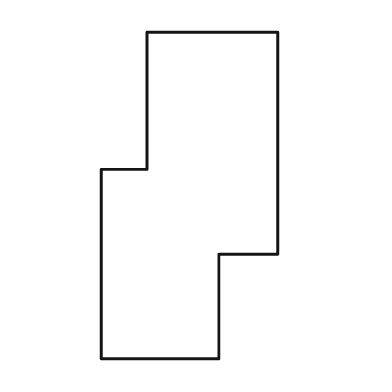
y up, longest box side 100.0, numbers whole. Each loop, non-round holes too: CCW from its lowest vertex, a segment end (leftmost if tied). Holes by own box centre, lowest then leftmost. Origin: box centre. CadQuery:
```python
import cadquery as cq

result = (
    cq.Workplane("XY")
    .moveTo(-27.0, -50.0)
    .lineTo(9.0, -50.0)
    .lineTo(9.0, -18.0)
    .lineTo(27.0, -18.0)
    .lineTo(27.0, 50.0)
    .lineTo(-13.0, 50.0)
    .lineTo(-13.0, 8.0)
    .lineTo(-27.0, 8.0)
    .close()
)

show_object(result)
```